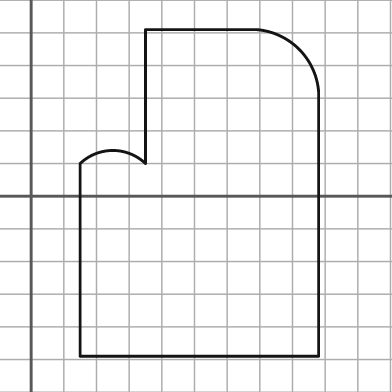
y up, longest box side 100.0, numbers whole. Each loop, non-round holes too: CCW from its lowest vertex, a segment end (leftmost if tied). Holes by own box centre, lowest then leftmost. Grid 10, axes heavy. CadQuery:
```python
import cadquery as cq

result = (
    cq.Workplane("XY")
    .moveTo(15.0, -49.0)
    .lineTo(88.0, -49.0)
    .lineTo(88.0, 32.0)
    .threePointArc((82.0, 45.0), (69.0, 51.0))
    .lineTo(35.0, 51.0)
    .lineTo(35.0, 10.0)
    .threePointArc((25.0, 14.0), (15.0, 10.0))
    .close()
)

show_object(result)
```